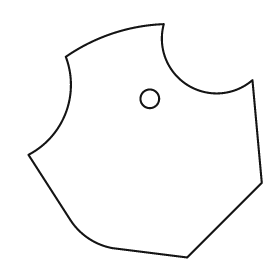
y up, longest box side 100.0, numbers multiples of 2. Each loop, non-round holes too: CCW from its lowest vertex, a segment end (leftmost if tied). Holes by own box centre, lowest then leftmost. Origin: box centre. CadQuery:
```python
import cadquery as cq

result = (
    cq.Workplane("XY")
    .moveTo(18.0, -50.0)
    .lineTo(50.0, -18.0)
    .lineTo(46.0, 26.0)
    .threePointArc((18.0, 24.0), (8.0, 50.0))
    .threePointArc((-14.0, 46.0), (-34.0, 36.0))
    .threePointArc((-34.0, 12.0), (-50.0, -6.0))
    .lineTo(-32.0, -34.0)
    .threePointArc((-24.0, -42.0), (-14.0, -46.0))
    .close()
    .moveTo(2.0, 18.0)
    .circle(4.0)
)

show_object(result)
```